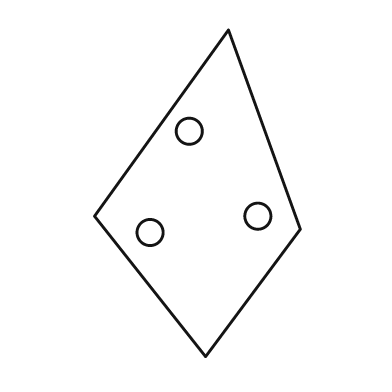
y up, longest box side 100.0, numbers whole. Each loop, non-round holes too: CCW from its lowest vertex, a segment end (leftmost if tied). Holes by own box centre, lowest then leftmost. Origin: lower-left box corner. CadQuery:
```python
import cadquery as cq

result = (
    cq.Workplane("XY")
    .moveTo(34.0, 0.0)
    .lineTo(63.0, 39.0)
    .lineTo(41.0, 100.0)
    .lineTo(0.0, 43.0)
    .close()
    .moveTo(17.0, 38.0)
    .circle(4.0)
    .moveTo(50.0, 43.0)
    .circle(4.0)
    .moveTo(29.0, 69.0)
    .circle(4.0)
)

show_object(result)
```